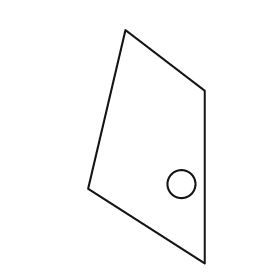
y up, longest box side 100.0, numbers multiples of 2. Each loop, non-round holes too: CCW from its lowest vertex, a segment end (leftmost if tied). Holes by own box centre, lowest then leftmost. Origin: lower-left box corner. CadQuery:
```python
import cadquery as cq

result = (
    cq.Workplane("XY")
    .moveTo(50.0, 0.0)
    .lineTo(50.0, 74.0)
    .lineTo(16.0, 100.0)
    .lineTo(0.0, 32.0)
    .close()
    .moveTo(40.0, 34.0)
    .circle(6.0)
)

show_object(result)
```